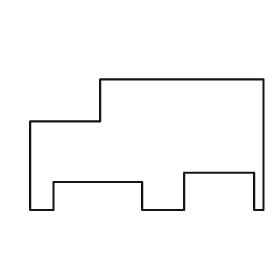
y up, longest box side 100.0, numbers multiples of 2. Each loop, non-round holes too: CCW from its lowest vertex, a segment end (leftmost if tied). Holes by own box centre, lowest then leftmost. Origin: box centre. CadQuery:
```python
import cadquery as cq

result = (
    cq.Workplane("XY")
    .moveTo(-50.0, -28.0)
    .lineTo(-40.0, -28.0)
    .lineTo(-40.0, -16.0)
    .lineTo(-2.0, -16.0)
    .lineTo(-2.0, -28.0)
    .lineTo(16.0, -28.0)
    .lineTo(16.0, -12.0)
    .lineTo(46.0, -12.0)
    .lineTo(46.0, -28.0)
    .lineTo(50.0, -28.0)
    .lineTo(50.0, 28.0)
    .lineTo(-20.0, 28.0)
    .lineTo(-20.0, 10.0)
    .lineTo(-50.0, 10.0)
    .close()
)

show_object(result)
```